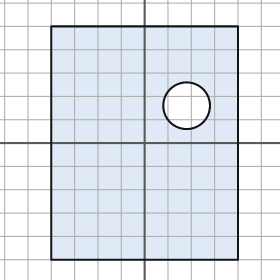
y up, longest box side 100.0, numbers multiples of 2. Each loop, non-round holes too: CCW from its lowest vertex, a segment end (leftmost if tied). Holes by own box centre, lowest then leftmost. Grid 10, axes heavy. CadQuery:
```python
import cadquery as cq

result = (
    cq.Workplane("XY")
    .moveTo(-40.0, -50.0)
    .lineTo(40.0, -50.0)
    .lineTo(40.0, 50.0)
    .lineTo(-40.0, 50.0)
    .close()
    .moveTo(18.0, 16.0)
    .circle(10.0)
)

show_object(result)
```